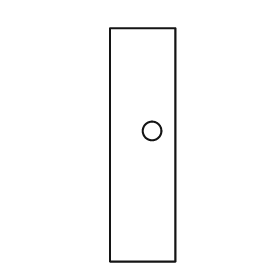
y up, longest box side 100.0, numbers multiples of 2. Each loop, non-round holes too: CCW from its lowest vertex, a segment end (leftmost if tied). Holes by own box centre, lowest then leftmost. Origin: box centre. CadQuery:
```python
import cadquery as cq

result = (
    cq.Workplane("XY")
    .moveTo(-14.0, -50.0)
    .lineTo(14.0, -50.0)
    .lineTo(14.0, 50.0)
    .lineTo(-14.0, 50.0)
    .close()
    .moveTo(4.0, 6.0)
    .circle(4.0)
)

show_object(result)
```